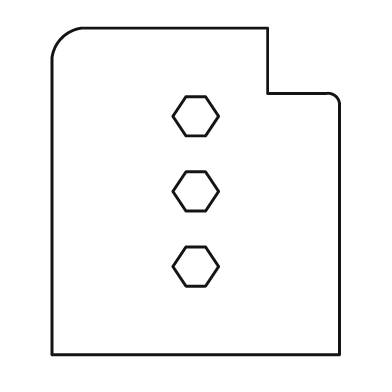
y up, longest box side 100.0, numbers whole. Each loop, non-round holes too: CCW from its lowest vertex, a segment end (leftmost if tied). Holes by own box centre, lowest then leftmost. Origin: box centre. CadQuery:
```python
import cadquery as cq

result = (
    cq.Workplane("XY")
    .moveTo(-44.0, -50.0)
    .lineTo(44.0, -50.0)
    .lineTo(44.0, 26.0)
    .threePointArc((43.0, 29.0), (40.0, 30.0))
    .lineTo(22.0, 30.0)
    .lineTo(22.0, 50.0)
    .lineTo(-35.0, 50.0)
    .threePointArc((-41.0, 47.0), (-44.0, 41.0))
    .close()
    .moveTo(-3.0, -29.0)
    .lineTo(3.0, -29.0)
    .lineTo(7.0, -23.0)
    .lineTo(3.0, -17.0)
    .lineTo(-3.0, -17.0)
    .lineTo(-7.0, -23.0)
    .close()
    .moveTo(-3.0, -6.0)
    .lineTo(3.0, -6.0)
    .lineTo(7.0, 0.0)
    .lineTo(3.0, 6.0)
    .lineTo(-3.0, 6.0)
    .lineTo(-7.0, 0.0)
    .close()
    .moveTo(-3.0, 17.0)
    .lineTo(3.0, 17.0)
    .lineTo(7.0, 23.0)
    .lineTo(3.0, 29.0)
    .lineTo(-3.0, 29.0)
    .lineTo(-7.0, 23.0)
    .close()
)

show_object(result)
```